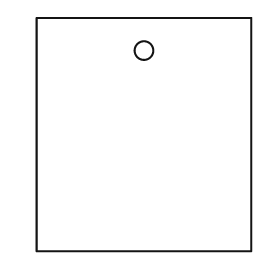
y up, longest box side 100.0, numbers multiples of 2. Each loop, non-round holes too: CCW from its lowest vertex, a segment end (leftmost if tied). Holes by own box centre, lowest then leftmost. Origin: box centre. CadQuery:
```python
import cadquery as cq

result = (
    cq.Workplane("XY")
    .moveTo(-46.0, -50.0)
    .lineTo(46.0, -50.0)
    .lineTo(46.0, 50.0)
    .lineTo(-46.0, 50.0)
    .close()
    .moveTo(0.0, 36.0)
    .circle(4.0)
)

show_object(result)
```